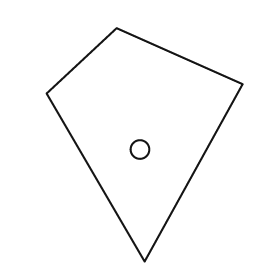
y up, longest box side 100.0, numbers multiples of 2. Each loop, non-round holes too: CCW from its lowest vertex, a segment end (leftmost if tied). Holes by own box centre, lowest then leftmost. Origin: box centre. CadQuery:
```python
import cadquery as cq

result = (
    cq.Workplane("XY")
    .moveTo(0.0, -50.0)
    .lineTo(42.0, 26.0)
    .lineTo(-12.0, 50.0)
    .lineTo(-42.0, 22.0)
    .close()
    .moveTo(-2.0, -2.0)
    .circle(4.0)
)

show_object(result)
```